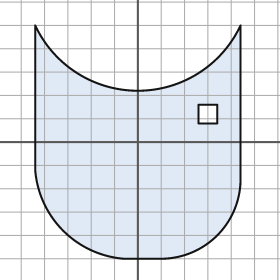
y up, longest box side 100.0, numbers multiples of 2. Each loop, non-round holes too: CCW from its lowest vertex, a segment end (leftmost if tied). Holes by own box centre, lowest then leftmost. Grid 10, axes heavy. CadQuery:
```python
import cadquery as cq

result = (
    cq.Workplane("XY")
    .moveTo(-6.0, -50.0)
    .lineTo(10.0, -50.0)
    .threePointArc((34.0, -40.0), (44.0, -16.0))
    .lineTo(44.0, 50.0)
    .threePointArc((0.0, 22.0), (-44.0, 50.0))
    .lineTo(-44.0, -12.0)
    .threePointArc((-32.0, -38.0), (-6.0, -50.0))
    .close()
    .moveTo(26.0, 8.0)
    .lineTo(34.0, 8.0)
    .lineTo(34.0, 16.0)
    .lineTo(26.0, 16.0)
    .close()
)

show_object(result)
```